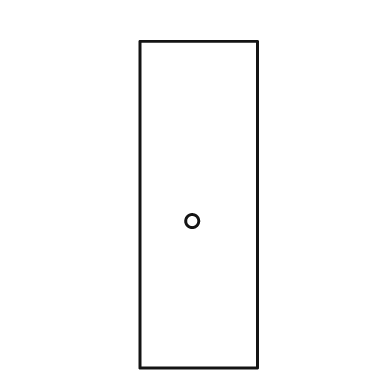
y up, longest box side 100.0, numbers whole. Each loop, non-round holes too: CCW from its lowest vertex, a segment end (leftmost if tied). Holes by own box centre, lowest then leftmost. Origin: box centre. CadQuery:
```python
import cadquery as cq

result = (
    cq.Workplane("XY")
    .moveTo(-18.0, -50.0)
    .lineTo(18.0, -50.0)
    .lineTo(18.0, 50.0)
    .lineTo(-18.0, 50.0)
    .close()
    .moveTo(-2.0, -5.0)
    .circle(2.0)
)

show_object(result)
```